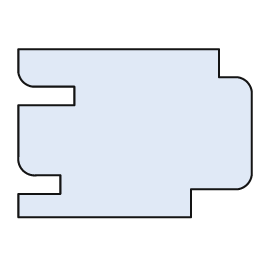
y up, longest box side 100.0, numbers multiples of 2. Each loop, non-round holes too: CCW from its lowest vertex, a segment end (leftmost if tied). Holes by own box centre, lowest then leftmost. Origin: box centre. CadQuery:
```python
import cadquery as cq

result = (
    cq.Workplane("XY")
    .moveTo(-50.0, -36.0)
    .lineTo(24.0, -36.0)
    .lineTo(24.0, -24.0)
    .lineTo(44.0, -24.0)
    .threePointArc((48.0, -22.0), (50.0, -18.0))
    .lineTo(50.0, 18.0)
    .threePointArc((48.0, 22.0), (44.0, 24.0))
    .lineTo(36.0, 24.0)
    .lineTo(36.0, 36.0)
    .lineTo(-50.0, 36.0)
    .lineTo(-50.0, 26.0)
    .threePointArc((-48.0, 22.0), (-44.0, 20.0))
    .lineTo(-26.0, 20.0)
    .lineTo(-26.0, 12.0)
    .lineTo(-50.0, 12.0)
    .lineTo(-50.0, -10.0)
    .threePointArc((-48.0, -16.0), (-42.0, -18.0))
    .lineTo(-32.0, -18.0)
    .lineTo(-32.0, -26.0)
    .lineTo(-50.0, -26.0)
    .close()
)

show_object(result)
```